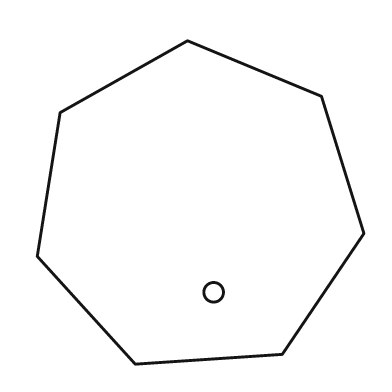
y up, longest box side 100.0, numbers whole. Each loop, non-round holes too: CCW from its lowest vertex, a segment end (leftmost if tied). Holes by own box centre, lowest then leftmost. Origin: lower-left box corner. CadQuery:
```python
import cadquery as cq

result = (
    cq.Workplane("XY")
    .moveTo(30.0, 0.0)
    .lineTo(75.0, 3.0)
    .lineTo(100.0, 40.0)
    .lineTo(87.0, 82.0)
    .lineTo(46.0, 99.0)
    .lineTo(7.0, 77.0)
    .lineTo(0.0, 33.0)
    .close()
    .moveTo(54.0, 22.0)
    .circle(3.0)
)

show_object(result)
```